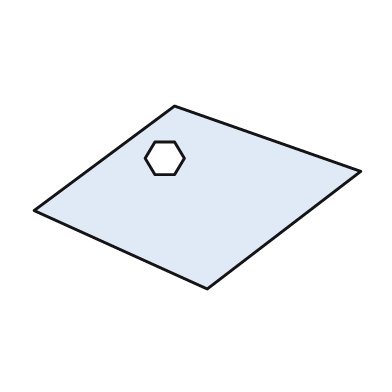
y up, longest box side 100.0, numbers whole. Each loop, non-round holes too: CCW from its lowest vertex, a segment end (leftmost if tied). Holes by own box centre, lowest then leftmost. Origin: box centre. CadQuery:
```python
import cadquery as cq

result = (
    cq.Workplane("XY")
    .moveTo(3.0, -28.0)
    .lineTo(50.0, 8.0)
    .lineTo(-7.0, 28.0)
    .lineTo(-50.0, -4.0)
    .close()
    .moveTo(-13.0, 7.0)
    .lineTo(-7.0, 7.0)
    .lineTo(-4.0, 12.0)
    .lineTo(-7.0, 17.0)
    .lineTo(-13.0, 17.0)
    .lineTo(-16.0, 12.0)
    .close()
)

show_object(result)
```